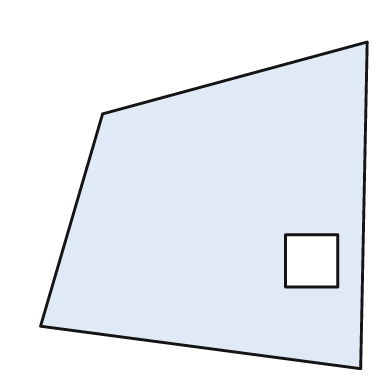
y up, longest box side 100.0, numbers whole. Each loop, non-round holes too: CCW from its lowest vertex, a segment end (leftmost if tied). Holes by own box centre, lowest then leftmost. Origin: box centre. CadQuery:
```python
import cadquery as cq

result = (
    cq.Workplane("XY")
    .moveTo(48.0, -50.0)
    .lineTo(50.0, 50.0)
    .lineTo(-31.0, 28.0)
    .lineTo(-50.0, -37.0)
    .close()
    .moveTo(25.0, -25.0)
    .lineTo(41.0, -25.0)
    .lineTo(41.0, -9.0)
    .lineTo(25.0, -9.0)
    .close()
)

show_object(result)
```